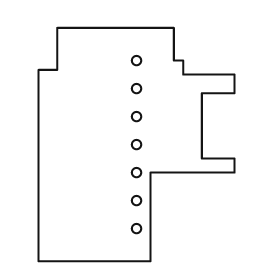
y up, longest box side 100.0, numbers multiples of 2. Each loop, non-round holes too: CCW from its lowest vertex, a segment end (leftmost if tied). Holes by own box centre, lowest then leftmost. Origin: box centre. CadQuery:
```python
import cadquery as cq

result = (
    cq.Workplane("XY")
    .moveTo(-42.0, -50.0)
    .lineTo(6.0, -50.0)
    .lineTo(6.0, -12.0)
    .lineTo(42.0, -12.0)
    .lineTo(42.0, -6.0)
    .lineTo(28.0, -6.0)
    .lineTo(28.0, 22.0)
    .lineTo(42.0, 22.0)
    .lineTo(42.0, 30.0)
    .lineTo(20.0, 30.0)
    .lineTo(20.0, 36.0)
    .lineTo(16.0, 36.0)
    .lineTo(16.0, 50.0)
    .lineTo(-34.0, 50.0)
    .lineTo(-34.0, 32.0)
    .lineTo(-42.0, 32.0)
    .close()
    .moveTo(0.0, -36.0)
    .circle(2.0)
    .moveTo(0.0, -24.0)
    .circle(2.0)
    .moveTo(0.0, -12.0)
    .circle(2.0)
    .moveTo(0.0, 0.0)
    .circle(2.0)
    .moveTo(0.0, 12.0)
    .circle(2.0)
    .moveTo(0.0, 24.0)
    .circle(2.0)
    .moveTo(0.0, 36.0)
    .circle(2.0)
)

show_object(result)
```